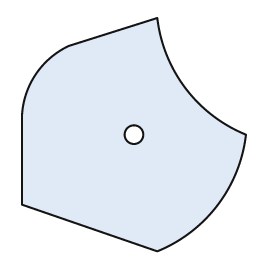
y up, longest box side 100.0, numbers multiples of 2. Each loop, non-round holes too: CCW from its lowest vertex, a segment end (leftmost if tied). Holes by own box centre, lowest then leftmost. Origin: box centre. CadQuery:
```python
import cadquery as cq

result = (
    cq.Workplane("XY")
    .moveTo(10.0, -50.0)
    .threePointArc((36.0, -30.0), (48.0, 0.0))
    .threePointArc((22.0, 20.0), (10.0, 50.0))
    .lineTo(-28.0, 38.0)
    .threePointArc((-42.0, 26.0), (-48.0, 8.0))
    .lineTo(-48.0, -30.0)
    .close()
    .moveTo(0.0, 0.0)
    .circle(4.0)
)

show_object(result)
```